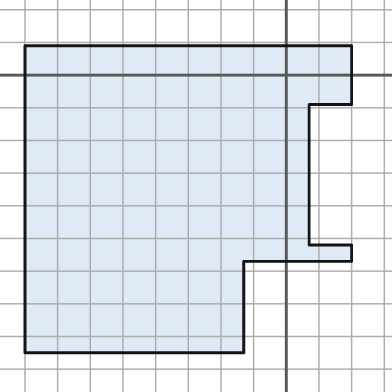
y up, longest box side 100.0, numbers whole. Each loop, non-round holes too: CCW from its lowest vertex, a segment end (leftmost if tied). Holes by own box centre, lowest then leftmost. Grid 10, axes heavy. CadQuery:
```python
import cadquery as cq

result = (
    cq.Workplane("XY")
    .moveTo(-80.0, -85.0)
    .lineTo(-13.0, -85.0)
    .lineTo(-13.0, -57.0)
    .lineTo(20.0, -57.0)
    .lineTo(20.0, -52.0)
    .lineTo(7.0, -52.0)
    .lineTo(7.0, -9.0)
    .lineTo(20.0, -9.0)
    .lineTo(20.0, 9.0)
    .lineTo(-80.0, 9.0)
    .close()
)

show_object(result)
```